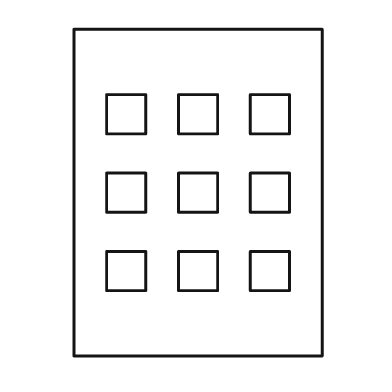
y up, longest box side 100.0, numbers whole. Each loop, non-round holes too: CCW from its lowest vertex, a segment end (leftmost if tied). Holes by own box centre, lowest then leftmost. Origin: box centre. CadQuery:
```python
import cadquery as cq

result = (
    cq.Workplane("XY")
    .moveTo(-38.0, -50.0)
    .lineTo(38.0, -50.0)
    .lineTo(38.0, 50.0)
    .lineTo(-38.0, 50.0)
    .close()
    .moveTo(-28.0, -30.0)
    .lineTo(-16.0, -30.0)
    .lineTo(-16.0, -18.0)
    .lineTo(-28.0, -18.0)
    .close()
    .moveTo(-6.0, -30.0)
    .lineTo(6.0, -30.0)
    .lineTo(6.0, -18.0)
    .lineTo(-6.0, -18.0)
    .close()
    .moveTo(16.0, -30.0)
    .lineTo(28.0, -30.0)
    .lineTo(28.0, -18.0)
    .lineTo(16.0, -18.0)
    .close()
    .moveTo(-28.0, -6.0)
    .lineTo(-16.0, -6.0)
    .lineTo(-16.0, 6.0)
    .lineTo(-28.0, 6.0)
    .close()
    .moveTo(-6.0, -6.0)
    .lineTo(6.0, -6.0)
    .lineTo(6.0, 6.0)
    .lineTo(-6.0, 6.0)
    .close()
    .moveTo(16.0, -6.0)
    .lineTo(28.0, -6.0)
    .lineTo(28.0, 6.0)
    .lineTo(16.0, 6.0)
    .close()
    .moveTo(-28.0, 18.0)
    .lineTo(-16.0, 18.0)
    .lineTo(-16.0, 30.0)
    .lineTo(-28.0, 30.0)
    .close()
    .moveTo(-6.0, 18.0)
    .lineTo(6.0, 18.0)
    .lineTo(6.0, 30.0)
    .lineTo(-6.0, 30.0)
    .close()
    .moveTo(16.0, 18.0)
    .lineTo(28.0, 18.0)
    .lineTo(28.0, 30.0)
    .lineTo(16.0, 30.0)
    .close()
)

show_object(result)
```